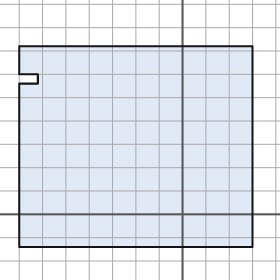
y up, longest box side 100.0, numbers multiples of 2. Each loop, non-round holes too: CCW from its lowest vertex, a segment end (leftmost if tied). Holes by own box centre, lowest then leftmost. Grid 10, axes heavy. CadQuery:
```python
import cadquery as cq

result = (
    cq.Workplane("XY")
    .moveTo(-70.0, -14.0)
    .lineTo(30.0, -14.0)
    .lineTo(30.0, 72.0)
    .lineTo(-70.0, 72.0)
    .lineTo(-70.0, 60.0)
    .lineTo(-62.0, 60.0)
    .lineTo(-62.0, 56.0)
    .lineTo(-70.0, 56.0)
    .close()
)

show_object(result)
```